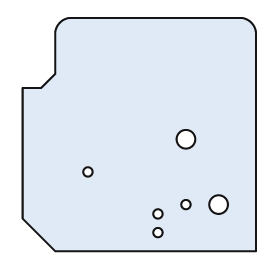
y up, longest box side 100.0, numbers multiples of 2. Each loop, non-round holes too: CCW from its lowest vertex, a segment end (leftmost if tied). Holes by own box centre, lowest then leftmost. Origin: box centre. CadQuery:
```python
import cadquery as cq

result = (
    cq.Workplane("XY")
    .moveTo(-36.0, -50.0)
    .lineTo(50.0, -50.0)
    .lineTo(50.0, 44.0)
    .threePointArc((48.0, 48.0), (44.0, 50.0))
    .lineTo(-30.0, 50.0)
    .threePointArc((-34.0, 48.0), (-36.0, 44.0))
    .lineTo(-36.0, 26.0)
    .lineTo(-42.0, 20.0)
    .lineTo(-50.0, 20.0)
    .lineTo(-50.0, -36.0)
    .close()
    .moveTo(8.0, -42.0)
    .circle(2.0)
    .moveTo(8.0, -34.0)
    .circle(2.0)
    .moveTo(20.0, -30.0)
    .circle(2.0)
    .moveTo(34.0, -30.0)
    .circle(4.0)
    .moveTo(-22.0, -16.0)
    .circle(2.0)
    .moveTo(20.0, -2.0)
    .circle(4.0)
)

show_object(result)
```